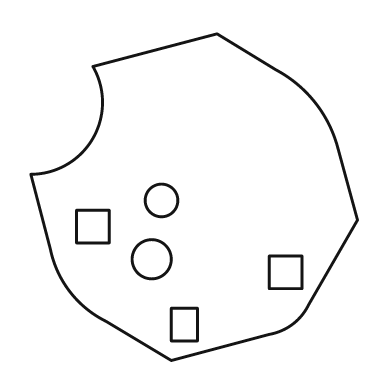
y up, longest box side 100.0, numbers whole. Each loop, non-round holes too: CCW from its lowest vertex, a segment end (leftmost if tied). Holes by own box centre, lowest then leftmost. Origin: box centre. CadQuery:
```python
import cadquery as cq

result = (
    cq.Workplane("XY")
    .moveTo(-7.0, -50.0)
    .lineTo(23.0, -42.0)
    .threePointArc((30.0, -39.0), (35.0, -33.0))
    .lineTo(50.0, -7.0)
    .lineTo(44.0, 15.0)
    .threePointArc((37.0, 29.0), (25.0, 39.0))
    .lineTo(7.0, 50.0)
    .lineTo(-31.0, 40.0)
    .threePointArc((-31.0, 18.0), (-50.0, 7.0))
    .lineTo(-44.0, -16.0)
    .threePointArc((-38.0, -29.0), (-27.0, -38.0))
    .close()
    .moveTo(-7.0, -44.0)
    .lineTo(1.0, -44.0)
    .lineTo(1.0, -34.0)
    .lineTo(-7.0, -34.0)
    .close()
    .moveTo(23.0, -28.0)
    .lineTo(33.0, -28.0)
    .lineTo(33.0, -18.0)
    .lineTo(23.0, -18.0)
    .close()
    .moveTo(-13.0, -19.0)
    .circle(6.0)
    .moveTo(-36.0, -14.0)
    .lineTo(-26.0, -14.0)
    .lineTo(-26.0, -4.0)
    .lineTo(-36.0, -4.0)
    .close()
    .moveTo(-10.0, -1.0)
    .circle(5.0)
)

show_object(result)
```